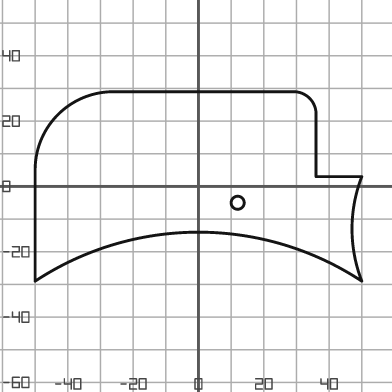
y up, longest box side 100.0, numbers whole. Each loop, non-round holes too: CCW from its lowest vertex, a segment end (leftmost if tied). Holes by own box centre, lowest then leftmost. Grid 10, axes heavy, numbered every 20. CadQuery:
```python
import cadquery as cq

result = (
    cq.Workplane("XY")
    .moveTo(-50.0, -29.0)
    .threePointArc((0.0, -14.0), (50.0, -29.0))
    .threePointArc((47.0, -13.0), (50.0, 3.0))
    .lineTo(36.0, 3.0)
    .lineTo(36.0, 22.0)
    .threePointArc((34.0, 27.0), (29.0, 29.0))
    .lineTo(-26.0, 29.0)
    .threePointArc((-43.0, 22.0), (-50.0, 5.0))
    .close()
    .moveTo(12.0, -5.0)
    .circle(2.0)
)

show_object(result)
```